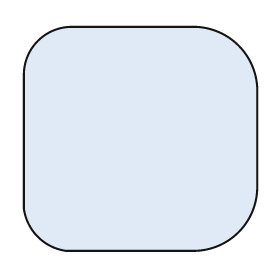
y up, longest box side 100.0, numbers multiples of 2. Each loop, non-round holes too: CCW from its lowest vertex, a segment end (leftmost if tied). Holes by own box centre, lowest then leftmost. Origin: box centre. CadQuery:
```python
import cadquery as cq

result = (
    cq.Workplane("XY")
    .moveTo(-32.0, -48.0)
    .lineTo(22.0, -48.0)
    .threePointArc((42.0, -40.0), (50.0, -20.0))
    .lineTo(50.0, 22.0)
    .threePointArc((42.0, 40.0), (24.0, 48.0))
    .lineTo(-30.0, 48.0)
    .threePointArc((-44.0, 42.0), (-50.0, 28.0))
    .lineTo(-50.0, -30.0)
    .threePointArc((-44.0, -42.0), (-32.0, -48.0))
    .close()
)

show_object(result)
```